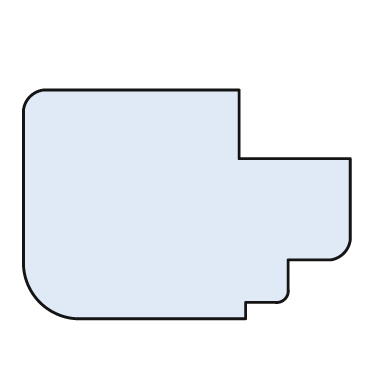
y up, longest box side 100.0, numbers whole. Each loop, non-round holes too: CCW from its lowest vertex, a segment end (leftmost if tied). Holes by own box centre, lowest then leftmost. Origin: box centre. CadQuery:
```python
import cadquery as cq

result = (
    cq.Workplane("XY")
    .moveTo(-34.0, -35.0)
    .lineTo(18.0, -35.0)
    .lineTo(18.0, -30.0)
    .lineTo(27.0, -30.0)
    .threePointArc((30.0, -29.0), (31.0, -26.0))
    .lineTo(31.0, -17.0)
    .lineTo(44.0, -17.0)
    .threePointArc((48.0, -15.0), (50.0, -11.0))
    .lineTo(50.0, 14.0)
    .lineTo(16.0, 14.0)
    .lineTo(16.0, 35.0)
    .lineTo(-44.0, 35.0)
    .threePointArc((-48.0, 33.0), (-50.0, 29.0))
    .lineTo(-50.0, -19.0)
    .threePointArc((-45.0, -30.0), (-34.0, -35.0))
    .close()
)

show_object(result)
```